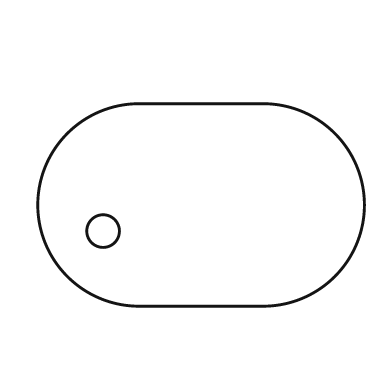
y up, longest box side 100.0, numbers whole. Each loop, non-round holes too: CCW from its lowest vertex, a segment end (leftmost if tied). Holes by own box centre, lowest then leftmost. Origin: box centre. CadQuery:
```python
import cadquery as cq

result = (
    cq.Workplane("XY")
    .moveTo(-19.0, -31.0)
    .lineTo(19.0, -31.0)
    .threePointArc((50.0, 0.0), (19.0, 31.0))
    .lineTo(-19.0, 31.0)
    .threePointArc((-50.0, 0.0), (-19.0, -31.0))
    .close()
    .moveTo(-30.0, -8.0)
    .circle(5.0)
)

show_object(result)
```